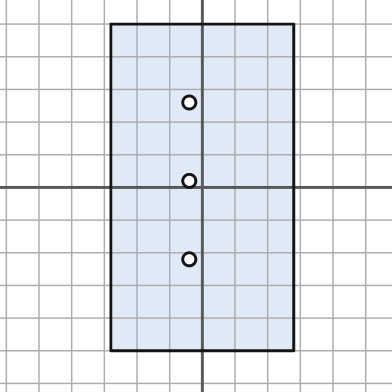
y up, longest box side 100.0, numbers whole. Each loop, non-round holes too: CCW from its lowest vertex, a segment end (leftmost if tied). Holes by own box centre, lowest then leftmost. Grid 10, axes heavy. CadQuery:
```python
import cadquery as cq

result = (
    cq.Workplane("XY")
    .moveTo(-28.0, -50.0)
    .lineTo(28.0, -50.0)
    .lineTo(28.0, 50.0)
    .lineTo(-28.0, 50.0)
    .close()
    .moveTo(-4.0, -22.0)
    .circle(2.0)
    .moveTo(-4.0, 2.0)
    .circle(2.0)
    .moveTo(-4.0, 26.0)
    .circle(2.0)
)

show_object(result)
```